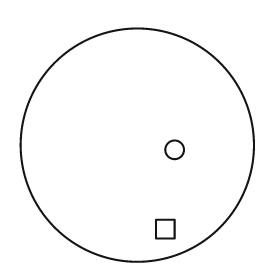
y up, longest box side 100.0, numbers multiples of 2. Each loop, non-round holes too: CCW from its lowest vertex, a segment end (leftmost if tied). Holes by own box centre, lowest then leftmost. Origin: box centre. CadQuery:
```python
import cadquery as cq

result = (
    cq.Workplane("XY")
    .moveTo(0.0, 0.0)
    .circle(50.0)
    .moveTo(8.0, -40.0)
    .lineTo(16.0, -40.0)
    .lineTo(16.0, -32.0)
    .lineTo(8.0, -32.0)
    .close()
    .moveTo(16.0, -2.0)
    .circle(4.0)
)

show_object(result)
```